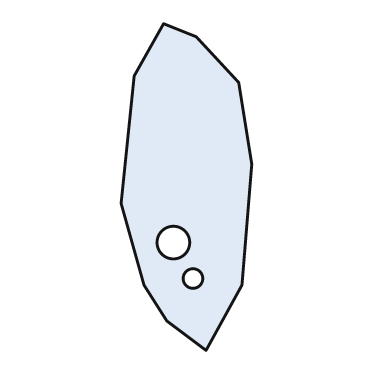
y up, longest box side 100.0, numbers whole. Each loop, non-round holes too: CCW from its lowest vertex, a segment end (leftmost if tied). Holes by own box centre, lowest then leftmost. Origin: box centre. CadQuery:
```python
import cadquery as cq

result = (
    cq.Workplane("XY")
    .moveTo(6.0, -50.0)
    .lineTo(17.0, -30.0)
    .lineTo(20.0, 7.0)
    .lineTo(16.0, 32.0)
    .lineTo(3.0, 46.0)
    .lineTo(-7.0, 50.0)
    .lineTo(-16.0, 34.0)
    .lineTo(-20.0, -5.0)
    .lineTo(-13.0, -30.0)
    .lineTo(-6.0, -41.0)
    .close()
    .moveTo(2.0, -28.0)
    .circle(3.0)
    .moveTo(-4.0, -17.0)
    .circle(5.0)
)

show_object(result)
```